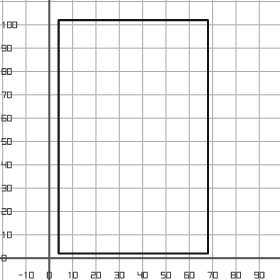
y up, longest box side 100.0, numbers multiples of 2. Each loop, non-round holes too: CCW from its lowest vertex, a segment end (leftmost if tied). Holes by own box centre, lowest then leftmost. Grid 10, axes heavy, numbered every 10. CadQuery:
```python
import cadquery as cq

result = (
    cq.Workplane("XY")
    .moveTo(4.0, 2.0)
    .lineTo(68.0, 2.0)
    .lineTo(68.0, 102.0)
    .lineTo(4.0, 102.0)
    .close()
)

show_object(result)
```